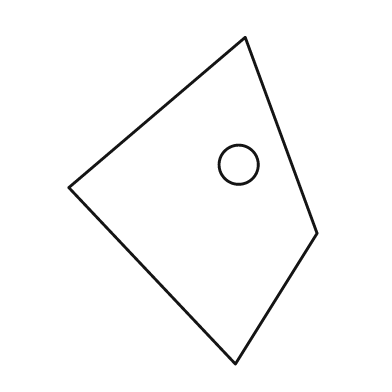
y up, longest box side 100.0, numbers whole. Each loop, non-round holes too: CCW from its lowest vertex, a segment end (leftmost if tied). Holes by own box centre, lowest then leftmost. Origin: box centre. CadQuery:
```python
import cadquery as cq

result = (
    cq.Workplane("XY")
    .moveTo(13.0, -50.0)
    .lineTo(38.0, -10.0)
    .lineTo(16.0, 50.0)
    .lineTo(-38.0, 4.0)
    .close()
    .moveTo(14.0, 11.0)
    .circle(6.0)
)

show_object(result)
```